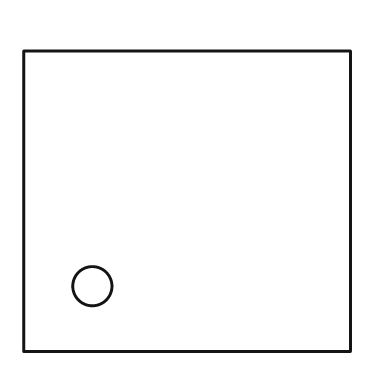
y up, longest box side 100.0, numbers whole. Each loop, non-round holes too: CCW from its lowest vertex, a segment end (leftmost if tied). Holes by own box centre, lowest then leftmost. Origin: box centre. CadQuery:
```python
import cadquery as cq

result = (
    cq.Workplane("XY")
    .moveTo(-50.0, -46.0)
    .lineTo(50.0, -46.0)
    .lineTo(50.0, 46.0)
    .lineTo(-50.0, 46.0)
    .close()
    .moveTo(-29.0, -26.0)
    .circle(6.0)
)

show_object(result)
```